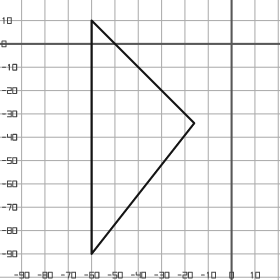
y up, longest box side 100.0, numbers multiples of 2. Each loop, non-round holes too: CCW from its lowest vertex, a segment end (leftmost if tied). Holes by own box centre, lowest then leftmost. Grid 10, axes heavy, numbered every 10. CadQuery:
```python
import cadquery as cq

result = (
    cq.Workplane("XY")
    .moveTo(-60.0, -90.0)
    .lineTo(-16.0, -34.0)
    .lineTo(-60.0, 10.0)
    .close()
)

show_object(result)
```